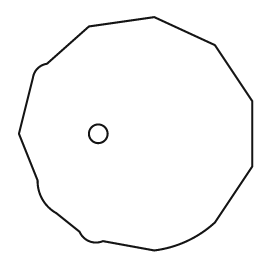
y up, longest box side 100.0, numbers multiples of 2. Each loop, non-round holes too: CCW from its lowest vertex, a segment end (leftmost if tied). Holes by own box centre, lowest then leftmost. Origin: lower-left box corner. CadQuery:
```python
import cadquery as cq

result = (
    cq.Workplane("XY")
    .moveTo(58.0, 0.0)
    .threePointArc((72.0, 4.0), (84.0, 12.0))
    .lineTo(100.0, 36.0)
    .lineTo(100.0, 64.0)
    .lineTo(84.0, 88.0)
    .lineTo(58.0, 100.0)
    .lineTo(30.0, 96.0)
    .lineTo(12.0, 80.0)
    .threePointArc((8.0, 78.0), (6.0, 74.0))
    .lineTo(0.0, 50.0)
    .lineTo(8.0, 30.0)
    .threePointArc((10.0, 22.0), (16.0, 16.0))
    .lineTo(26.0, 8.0)
    .threePointArc((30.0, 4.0), (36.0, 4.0))
    .close()
    .moveTo(34.0, 50.0)
    .circle(4.0)
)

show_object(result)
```